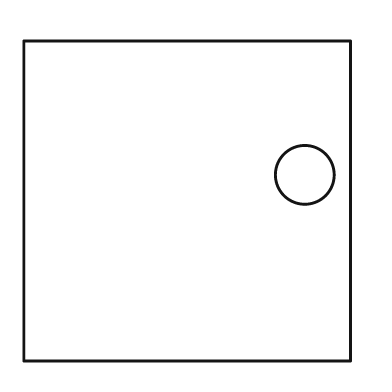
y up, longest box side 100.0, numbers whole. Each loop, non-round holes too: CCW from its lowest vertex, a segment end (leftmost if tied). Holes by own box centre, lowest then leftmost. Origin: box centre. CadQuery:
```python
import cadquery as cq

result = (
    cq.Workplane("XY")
    .moveTo(-50.0, -49.0)
    .lineTo(50.0, -49.0)
    .lineTo(50.0, 49.0)
    .lineTo(-50.0, 49.0)
    .close()
    .moveTo(36.0, 8.0)
    .circle(9.0)
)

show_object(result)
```